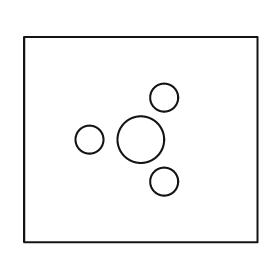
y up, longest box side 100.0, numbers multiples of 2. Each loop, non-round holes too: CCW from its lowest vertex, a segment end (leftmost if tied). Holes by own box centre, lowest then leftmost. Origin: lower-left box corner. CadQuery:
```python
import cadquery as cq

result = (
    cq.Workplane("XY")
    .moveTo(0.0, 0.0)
    .lineTo(100.0, 0.0)
    .lineTo(100.0, 88.0)
    .lineTo(0.0, 88.0)
    .close()
    .moveTo(60.0, 26.0)
    .circle(6.0)
    .moveTo(28.0, 44.0)
    .circle(6.0)
    .moveTo(50.0, 44.0)
    .circle(10.0)
    .moveTo(60.0, 62.0)
    .circle(6.0)
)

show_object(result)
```